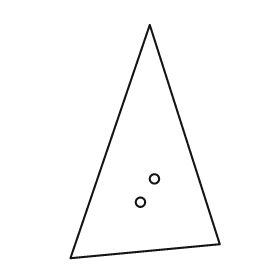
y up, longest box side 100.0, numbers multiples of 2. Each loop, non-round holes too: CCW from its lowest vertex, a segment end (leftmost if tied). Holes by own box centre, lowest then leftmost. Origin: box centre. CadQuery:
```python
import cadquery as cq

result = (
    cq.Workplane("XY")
    .moveTo(-32.0, -50.0)
    .lineTo(32.0, -44.0)
    .lineTo(2.0, 50.0)
    .close()
    .moveTo(-2.0, -26.0)
    .circle(2.0)
    .moveTo(4.0, -16.0)
    .circle(2.0)
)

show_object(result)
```